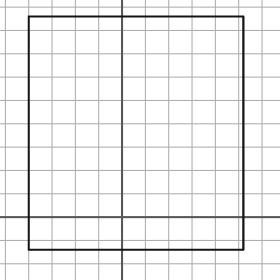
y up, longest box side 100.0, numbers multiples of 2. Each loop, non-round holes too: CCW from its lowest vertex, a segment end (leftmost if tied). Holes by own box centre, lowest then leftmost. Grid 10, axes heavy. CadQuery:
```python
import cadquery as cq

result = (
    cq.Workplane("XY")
    .moveTo(-40.0, -14.0)
    .lineTo(52.0, -14.0)
    .lineTo(52.0, 86.0)
    .lineTo(-40.0, 86.0)
    .close()
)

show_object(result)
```